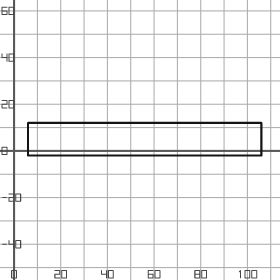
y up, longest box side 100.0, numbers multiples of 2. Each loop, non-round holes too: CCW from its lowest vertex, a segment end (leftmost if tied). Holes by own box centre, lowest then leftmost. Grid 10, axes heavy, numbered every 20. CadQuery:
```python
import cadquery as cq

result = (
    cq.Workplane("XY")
    .moveTo(6.0, -2.0)
    .lineTo(106.0, -2.0)
    .lineTo(106.0, 12.0)
    .lineTo(6.0, 12.0)
    .close()
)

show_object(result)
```